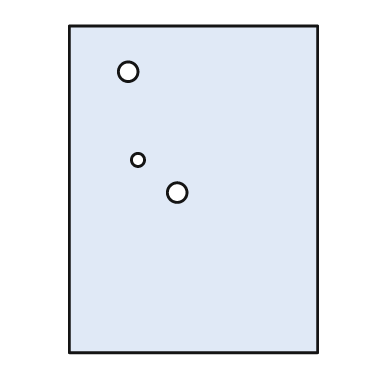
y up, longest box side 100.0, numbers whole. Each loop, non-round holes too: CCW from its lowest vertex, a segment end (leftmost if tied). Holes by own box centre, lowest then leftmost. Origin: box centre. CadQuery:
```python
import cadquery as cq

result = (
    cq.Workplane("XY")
    .moveTo(-38.0, -50.0)
    .lineTo(38.0, -50.0)
    .lineTo(38.0, 50.0)
    .lineTo(-38.0, 50.0)
    .close()
    .moveTo(-5.0, -1.0)
    .circle(3.0)
    .moveTo(-17.0, 9.0)
    .circle(2.0)
    .moveTo(-20.0, 36.0)
    .circle(3.0)
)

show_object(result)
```